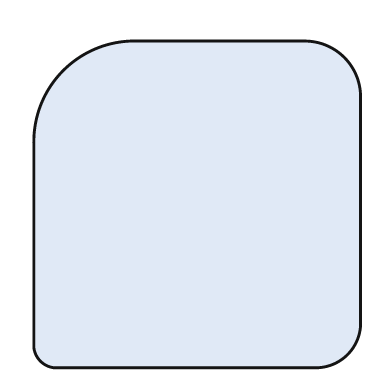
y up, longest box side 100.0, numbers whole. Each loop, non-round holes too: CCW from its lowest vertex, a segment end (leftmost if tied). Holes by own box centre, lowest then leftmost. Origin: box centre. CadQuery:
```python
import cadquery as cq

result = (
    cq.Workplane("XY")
    .moveTo(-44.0, -50.0)
    .lineTo(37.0, -50.0)
    .threePointArc((46.0, -46.0), (50.0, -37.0))
    .lineTo(50.0, 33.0)
    .threePointArc((45.0, 45.0), (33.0, 50.0))
    .lineTo(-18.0, 50.0)
    .threePointArc((-41.0, 41.0), (-50.0, 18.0))
    .lineTo(-50.0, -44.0)
    .threePointArc((-48.0, -48.0), (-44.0, -50.0))
    .close()
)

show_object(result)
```